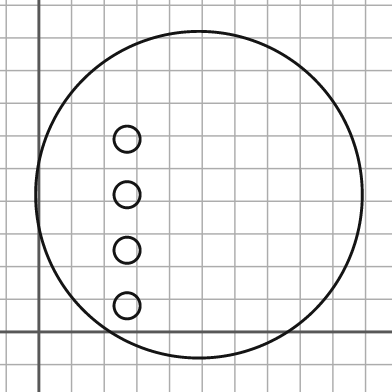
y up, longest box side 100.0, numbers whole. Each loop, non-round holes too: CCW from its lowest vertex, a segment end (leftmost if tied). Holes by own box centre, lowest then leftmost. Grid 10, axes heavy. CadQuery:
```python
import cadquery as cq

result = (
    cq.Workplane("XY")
    .moveTo(49.0, 42.0)
    .circle(50.0)
    .moveTo(27.0, 8.0)
    .circle(4.0)
    .moveTo(27.0, 25.0)
    .circle(4.0)
    .moveTo(27.0, 42.0)
    .circle(4.0)
    .moveTo(27.0, 59.0)
    .circle(4.0)
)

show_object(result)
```